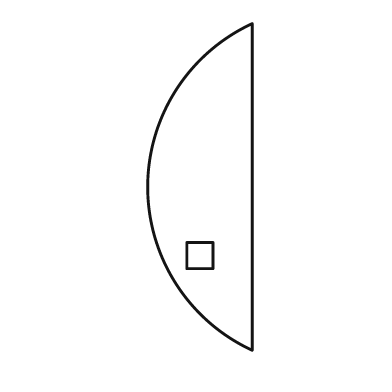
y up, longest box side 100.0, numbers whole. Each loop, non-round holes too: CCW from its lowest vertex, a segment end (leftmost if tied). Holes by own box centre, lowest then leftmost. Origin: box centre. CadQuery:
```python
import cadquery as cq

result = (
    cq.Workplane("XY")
    .moveTo(16.0, -50.0)
    .lineTo(16.0, 50.0)
    .threePointArc((-16.0, 0.0), (16.0, -50.0))
    .close()
    .moveTo(-4.0, -25.0)
    .lineTo(4.0, -25.0)
    .lineTo(4.0, -17.0)
    .lineTo(-4.0, -17.0)
    .close()
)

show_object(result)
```